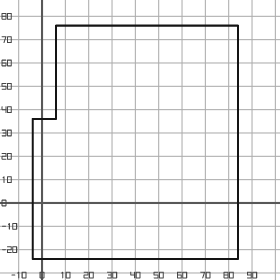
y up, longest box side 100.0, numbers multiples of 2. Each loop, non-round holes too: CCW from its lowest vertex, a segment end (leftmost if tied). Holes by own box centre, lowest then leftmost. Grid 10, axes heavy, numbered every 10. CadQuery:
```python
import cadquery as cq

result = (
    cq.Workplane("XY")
    .moveTo(-4.0, -24.0)
    .lineTo(84.0, -24.0)
    .lineTo(84.0, 76.0)
    .lineTo(6.0, 76.0)
    .lineTo(6.0, 36.0)
    .lineTo(-4.0, 36.0)
    .close()
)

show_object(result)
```